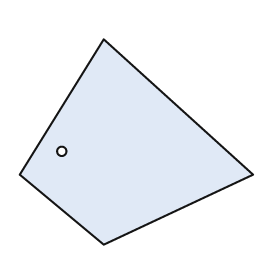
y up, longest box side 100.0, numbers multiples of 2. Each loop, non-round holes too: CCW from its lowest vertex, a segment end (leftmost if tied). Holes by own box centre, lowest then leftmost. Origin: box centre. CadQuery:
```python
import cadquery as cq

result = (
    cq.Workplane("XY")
    .moveTo(-14.0, -44.0)
    .lineTo(50.0, -14.0)
    .lineTo(-14.0, 44.0)
    .lineTo(-50.0, -14.0)
    .close()
    .moveTo(-32.0, -4.0)
    .circle(2.0)
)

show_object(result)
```